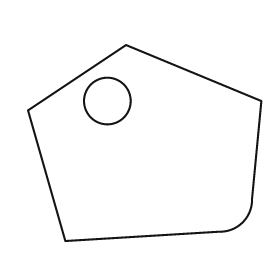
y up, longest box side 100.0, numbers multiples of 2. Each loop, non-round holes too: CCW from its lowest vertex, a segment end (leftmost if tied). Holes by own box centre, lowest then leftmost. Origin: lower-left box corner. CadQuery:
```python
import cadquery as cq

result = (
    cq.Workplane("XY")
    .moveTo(16.0, 0.0)
    .lineTo(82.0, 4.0)
    .threePointArc((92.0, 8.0), (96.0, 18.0))
    .lineTo(100.0, 60.0)
    .lineTo(42.0, 84.0)
    .lineTo(0.0, 56.0)
    .close()
    .moveTo(34.0, 60.0)
    .circle(10.0)
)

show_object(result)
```